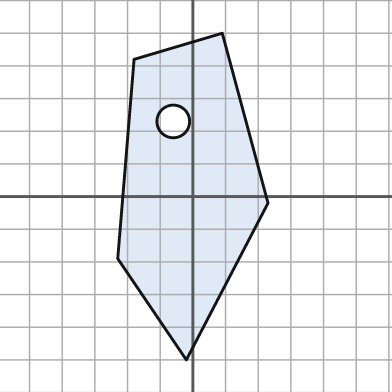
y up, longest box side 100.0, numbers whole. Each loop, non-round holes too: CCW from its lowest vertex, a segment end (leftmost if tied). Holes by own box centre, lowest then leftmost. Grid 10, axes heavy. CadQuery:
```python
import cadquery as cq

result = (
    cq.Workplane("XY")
    .moveTo(-2.0, -50.0)
    .lineTo(23.0, -2.0)
    .lineTo(9.0, 50.0)
    .lineTo(-18.0, 42.0)
    .lineTo(-23.0, -19.0)
    .close()
    .moveTo(-6.0, 23.0)
    .circle(5.0)
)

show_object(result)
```